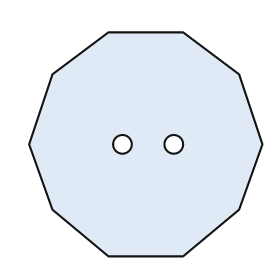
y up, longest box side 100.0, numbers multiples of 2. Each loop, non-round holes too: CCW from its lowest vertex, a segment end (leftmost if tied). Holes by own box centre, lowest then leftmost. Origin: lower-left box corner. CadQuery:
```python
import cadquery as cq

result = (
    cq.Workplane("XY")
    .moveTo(34.0, 0.0)
    .lineTo(66.0, 0.0)
    .lineTo(90.0, 20.0)
    .lineTo(100.0, 48.0)
    .lineTo(90.0, 78.0)
    .lineTo(66.0, 96.0)
    .lineTo(34.0, 96.0)
    .lineTo(10.0, 78.0)
    .lineTo(0.0, 48.0)
    .lineTo(10.0, 20.0)
    .close()
    .moveTo(40.0, 48.0)
    .circle(4.0)
    .moveTo(62.0, 48.0)
    .circle(4.0)
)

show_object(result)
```